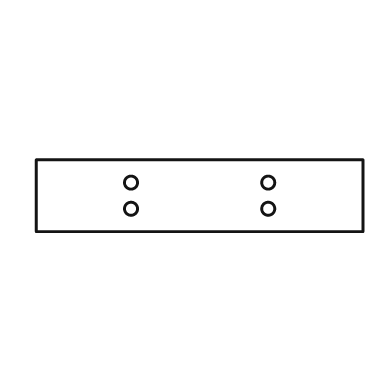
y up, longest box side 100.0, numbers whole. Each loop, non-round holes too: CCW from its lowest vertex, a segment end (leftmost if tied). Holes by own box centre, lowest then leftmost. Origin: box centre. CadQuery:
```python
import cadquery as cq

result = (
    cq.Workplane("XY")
    .moveTo(-50.0, -11.0)
    .lineTo(50.0, -11.0)
    .lineTo(50.0, 11.0)
    .lineTo(-50.0, 11.0)
    .close()
    .moveTo(-21.0, -4.0)
    .circle(2.0)
    .moveTo(21.0, -4.0)
    .circle(2.0)
    .moveTo(-21.0, 4.0)
    .circle(2.0)
    .moveTo(21.0, 4.0)
    .circle(2.0)
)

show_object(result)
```